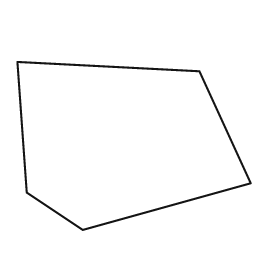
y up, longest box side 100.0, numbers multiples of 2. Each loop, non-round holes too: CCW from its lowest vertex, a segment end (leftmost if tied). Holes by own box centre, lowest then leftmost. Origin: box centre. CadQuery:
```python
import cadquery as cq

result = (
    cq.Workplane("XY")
    .moveTo(-22.0, -36.0)
    .lineTo(50.0, -16.0)
    .lineTo(28.0, 32.0)
    .lineTo(-50.0, 36.0)
    .lineTo(-46.0, -20.0)
    .close()
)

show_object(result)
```